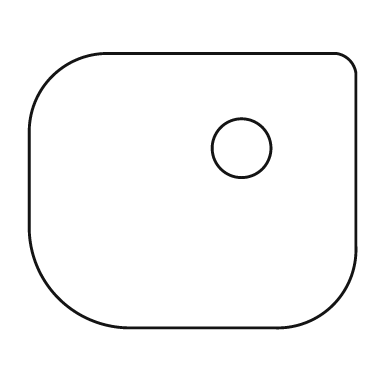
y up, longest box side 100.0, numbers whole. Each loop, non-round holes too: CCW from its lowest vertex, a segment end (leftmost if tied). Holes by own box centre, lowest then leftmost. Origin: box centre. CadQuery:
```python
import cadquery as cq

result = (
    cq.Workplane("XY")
    .moveTo(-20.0, -42.0)
    .lineTo(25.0, -42.0)
    .threePointArc((43.0, -35.0), (50.0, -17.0))
    .lineTo(50.0, 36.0)
    .threePointArc((48.0, 40.0), (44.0, 42.0))
    .lineTo(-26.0, 42.0)
    .threePointArc((-43.0, 35.0), (-50.0, 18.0))
    .lineTo(-50.0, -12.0)
    .threePointArc((-41.0, -33.0), (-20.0, -42.0))
    .close()
    .moveTo(15.0, 13.0)
    .circle(9.0)
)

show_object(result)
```